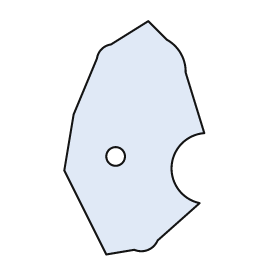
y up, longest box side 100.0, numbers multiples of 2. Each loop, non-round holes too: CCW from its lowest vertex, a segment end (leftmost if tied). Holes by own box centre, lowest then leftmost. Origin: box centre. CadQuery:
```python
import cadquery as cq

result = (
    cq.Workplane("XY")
    .moveTo(-12.0, -50.0)
    .lineTo(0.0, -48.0)
    .threePointArc((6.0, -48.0), (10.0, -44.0))
    .lineTo(28.0, -28.0)
    .threePointArc((16.0, -12.0), (30.0, 2.0))
    .lineTo(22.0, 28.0)
    .threePointArc((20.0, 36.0), (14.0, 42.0))
    .lineTo(6.0, 50.0)
    .lineTo(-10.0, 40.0)
    .threePointArc((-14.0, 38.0), (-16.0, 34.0))
    .lineTo(-26.0, 10.0)
    .lineTo(-30.0, -14.0)
    .close()
    .moveTo(-8.0, -8.0)
    .circle(4.0)
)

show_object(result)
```